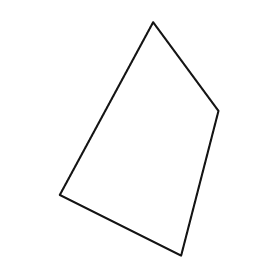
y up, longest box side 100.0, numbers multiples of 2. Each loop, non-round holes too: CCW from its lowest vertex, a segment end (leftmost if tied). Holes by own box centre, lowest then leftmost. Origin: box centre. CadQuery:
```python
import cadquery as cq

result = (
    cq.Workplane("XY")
    .moveTo(18.0, -50.0)
    .lineTo(34.0, 12.0)
    .lineTo(6.0, 50.0)
    .lineTo(-34.0, -24.0)
    .close()
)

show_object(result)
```